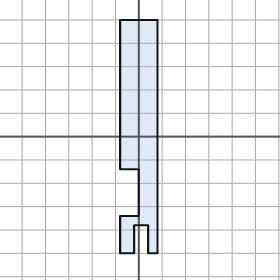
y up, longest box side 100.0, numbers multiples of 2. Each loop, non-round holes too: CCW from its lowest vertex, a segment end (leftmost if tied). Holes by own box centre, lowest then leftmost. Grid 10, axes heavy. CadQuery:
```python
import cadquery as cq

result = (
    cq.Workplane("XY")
    .moveTo(-8.0, -50.0)
    .lineTo(-2.0, -50.0)
    .lineTo(-2.0, -38.0)
    .lineTo(4.0, -38.0)
    .lineTo(4.0, -50.0)
    .lineTo(8.0, -50.0)
    .lineTo(8.0, 50.0)
    .lineTo(-8.0, 50.0)
    .lineTo(-8.0, -14.0)
    .lineTo(0.0, -14.0)
    .lineTo(0.0, -34.0)
    .lineTo(-8.0, -34.0)
    .close()
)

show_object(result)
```